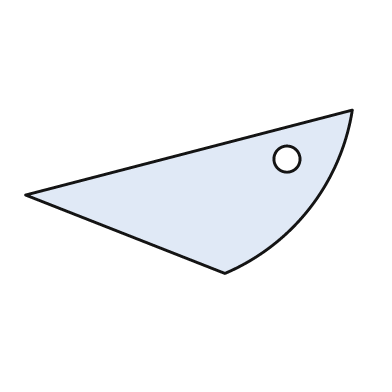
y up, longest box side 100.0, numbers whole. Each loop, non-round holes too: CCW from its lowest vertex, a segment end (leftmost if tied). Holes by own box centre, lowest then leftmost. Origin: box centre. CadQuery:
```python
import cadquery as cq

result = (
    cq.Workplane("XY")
    .moveTo(11.0, -25.0)
    .threePointArc((37.0, -5.0), (50.0, 25.0))
    .lineTo(-50.0, -1.0)
    .close()
    .moveTo(30.0, 10.0)
    .circle(4.0)
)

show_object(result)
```